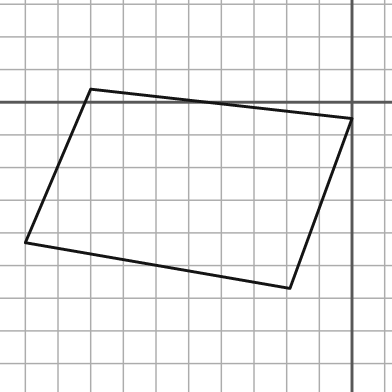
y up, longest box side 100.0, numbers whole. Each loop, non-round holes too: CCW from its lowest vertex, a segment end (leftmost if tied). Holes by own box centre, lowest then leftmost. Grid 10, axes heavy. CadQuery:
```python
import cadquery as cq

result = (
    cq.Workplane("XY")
    .moveTo(-19.0, -57.0)
    .lineTo(0.0, -5.0)
    .lineTo(-80.0, 4.0)
    .lineTo(-100.0, -43.0)
    .close()
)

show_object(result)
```